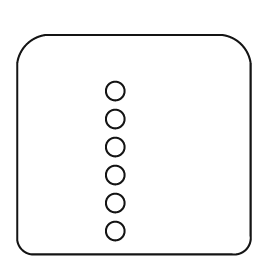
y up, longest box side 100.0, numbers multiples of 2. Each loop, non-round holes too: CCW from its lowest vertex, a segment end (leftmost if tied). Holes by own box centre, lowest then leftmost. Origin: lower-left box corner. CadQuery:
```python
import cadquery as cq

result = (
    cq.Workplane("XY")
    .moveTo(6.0, 0.0)
    .lineTo(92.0, 0.0)
    .threePointArc((98.0, 2.0), (100.0, 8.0))
    .lineTo(100.0, 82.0)
    .threePointArc((96.0, 90.0), (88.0, 94.0))
    .lineTo(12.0, 94.0)
    .threePointArc((4.0, 90.0), (0.0, 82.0))
    .lineTo(0.0, 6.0)
    .threePointArc((2.0, 2.0), (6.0, 0.0))
    .close()
    .moveTo(42.0, 10.0)
    .circle(4.0)
    .moveTo(42.0, 22.0)
    .circle(4.0)
    .moveTo(42.0, 34.0)
    .circle(4.0)
    .moveTo(42.0, 46.0)
    .circle(4.0)
    .moveTo(42.0, 58.0)
    .circle(4.0)
    .moveTo(42.0, 70.0)
    .circle(4.0)
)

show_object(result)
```